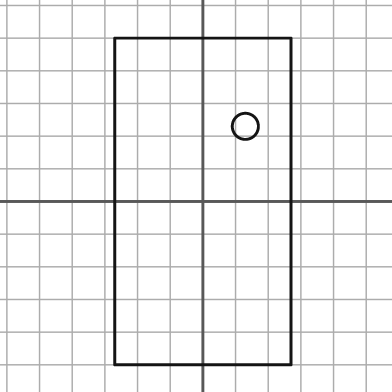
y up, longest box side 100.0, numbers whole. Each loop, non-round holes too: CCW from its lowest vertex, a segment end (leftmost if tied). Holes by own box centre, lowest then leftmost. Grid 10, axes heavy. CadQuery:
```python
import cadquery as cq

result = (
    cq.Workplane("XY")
    .moveTo(-27.0, -50.0)
    .lineTo(27.0, -50.0)
    .lineTo(27.0, 50.0)
    .lineTo(-27.0, 50.0)
    .close()
    .moveTo(13.0, 23.0)
    .circle(4.0)
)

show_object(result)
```